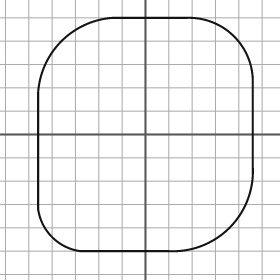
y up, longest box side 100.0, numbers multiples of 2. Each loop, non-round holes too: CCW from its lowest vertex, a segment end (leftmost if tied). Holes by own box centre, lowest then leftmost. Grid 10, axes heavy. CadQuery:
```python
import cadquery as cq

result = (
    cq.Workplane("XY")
    .moveTo(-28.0, -50.0)
    .lineTo(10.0, -50.0)
    .threePointArc((36.0, -40.0), (46.0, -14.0))
    .lineTo(46.0, 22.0)
    .threePointArc((38.0, 42.0), (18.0, 50.0))
    .lineTo(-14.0, 50.0)
    .threePointArc((-36.0, 40.0), (-46.0, 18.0))
    .lineTo(-46.0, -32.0)
    .threePointArc((-40.0, -44.0), (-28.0, -50.0))
    .close()
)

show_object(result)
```